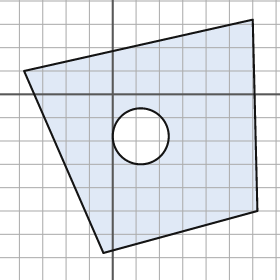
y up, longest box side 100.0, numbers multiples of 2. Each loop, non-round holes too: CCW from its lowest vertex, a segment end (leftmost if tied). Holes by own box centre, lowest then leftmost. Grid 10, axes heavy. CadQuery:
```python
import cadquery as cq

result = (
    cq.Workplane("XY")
    .moveTo(-4.0, -68.0)
    .lineTo(62.0, -50.0)
    .lineTo(60.0, 32.0)
    .lineTo(-38.0, 10.0)
    .close()
    .moveTo(12.0, -18.0)
    .circle(12.0)
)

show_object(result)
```